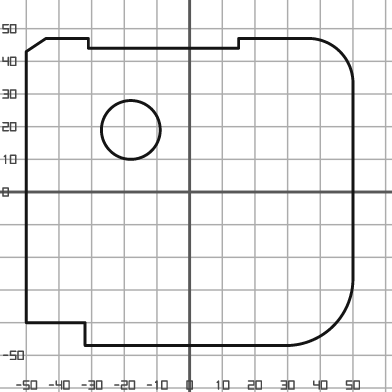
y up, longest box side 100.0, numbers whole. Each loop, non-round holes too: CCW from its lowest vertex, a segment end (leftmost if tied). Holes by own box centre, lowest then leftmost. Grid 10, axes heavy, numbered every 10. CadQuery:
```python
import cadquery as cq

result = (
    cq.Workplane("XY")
    .moveTo(-32.0, -47.0)
    .lineTo(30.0, -47.0)
    .threePointArc((44.0, -41.0), (50.0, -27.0))
    .lineTo(50.0, 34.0)
    .threePointArc((46.0, 43.0), (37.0, 47.0))
    .lineTo(15.0, 47.0)
    .lineTo(15.0, 44.0)
    .lineTo(-31.0, 44.0)
    .lineTo(-31.0, 47.0)
    .lineTo(-44.0, 47.0)
    .lineTo(-50.0, 43.0)
    .lineTo(-50.0, -40.0)
    .lineTo(-32.0, -40.0)
    .close()
    .moveTo(-18.0, 19.0)
    .circle(9.0)
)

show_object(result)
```